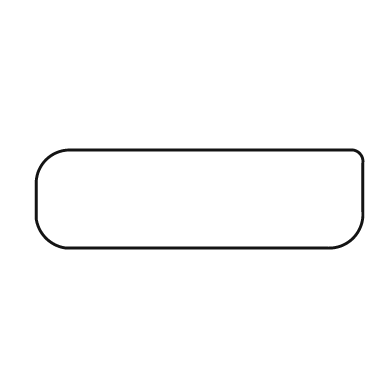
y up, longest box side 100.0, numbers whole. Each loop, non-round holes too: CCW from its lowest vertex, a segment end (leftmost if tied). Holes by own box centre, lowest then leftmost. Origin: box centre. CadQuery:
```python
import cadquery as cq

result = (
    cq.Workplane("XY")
    .moveTo(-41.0, -15.0)
    .lineTo(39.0, -15.0)
    .threePointArc((47.0, -12.0), (50.0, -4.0))
    .lineTo(50.0, 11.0)
    .threePointArc((49.0, 14.0), (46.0, 15.0))
    .lineTo(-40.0, 15.0)
    .threePointArc((-47.0, 12.0), (-50.0, 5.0))
    .lineTo(-50.0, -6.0)
    .threePointArc((-47.0, -12.0), (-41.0, -15.0))
    .close()
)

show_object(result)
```